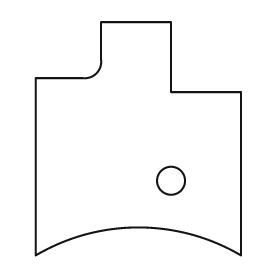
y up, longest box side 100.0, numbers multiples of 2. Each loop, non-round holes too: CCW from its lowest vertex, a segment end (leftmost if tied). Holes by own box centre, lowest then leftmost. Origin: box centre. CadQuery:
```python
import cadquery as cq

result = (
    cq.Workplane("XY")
    .moveTo(-44.0, -50.0)
    .threePointArc((0.0, -38.0), (44.0, -50.0))
    .lineTo(44.0, 20.0)
    .lineTo(14.0, 20.0)
    .lineTo(14.0, 50.0)
    .lineTo(-16.0, 50.0)
    .lineTo(-16.0, 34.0)
    .threePointArc((-18.0, 28.0), (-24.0, 26.0))
    .lineTo(-44.0, 26.0)
    .close()
    .moveTo(14.0, -18.0)
    .circle(6.0)
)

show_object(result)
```